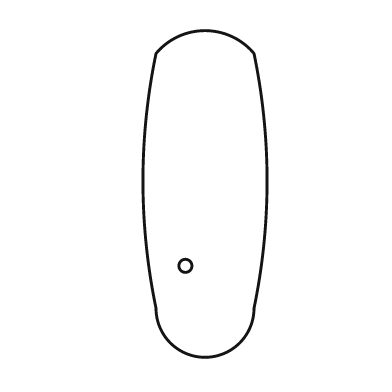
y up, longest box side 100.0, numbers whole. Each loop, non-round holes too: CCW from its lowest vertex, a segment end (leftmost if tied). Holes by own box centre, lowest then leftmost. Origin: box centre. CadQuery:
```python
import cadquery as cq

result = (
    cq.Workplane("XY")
    .moveTo(-15.0, -35.0)
    .threePointArc((0.0, -50.0), (15.0, -35.0))
    .threePointArc((19.0, 4.0), (15.0, 43.0))
    .threePointArc((0.0, 50.0), (-15.0, 43.0))
    .threePointArc((-19.0, 4.0), (-15.0, -35.0))
    .close()
    .moveTo(-6.0, -22.0)
    .circle(2.0)
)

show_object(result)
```